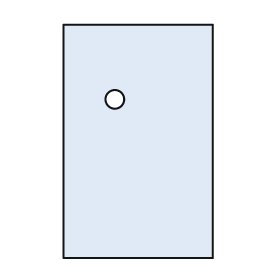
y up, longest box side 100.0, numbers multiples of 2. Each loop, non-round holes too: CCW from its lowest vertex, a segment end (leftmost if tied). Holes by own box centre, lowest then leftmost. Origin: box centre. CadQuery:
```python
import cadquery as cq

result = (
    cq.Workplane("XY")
    .moveTo(-32.0, -50.0)
    .lineTo(32.0, -50.0)
    .lineTo(32.0, 50.0)
    .lineTo(-32.0, 50.0)
    .close()
    .moveTo(-10.0, 18.0)
    .circle(4.0)
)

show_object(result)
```